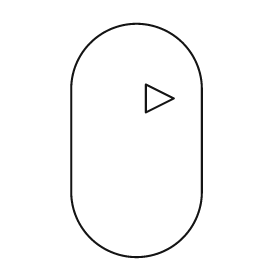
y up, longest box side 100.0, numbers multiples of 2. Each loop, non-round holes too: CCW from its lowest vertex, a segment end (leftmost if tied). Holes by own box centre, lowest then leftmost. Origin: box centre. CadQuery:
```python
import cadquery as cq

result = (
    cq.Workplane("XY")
    .moveTo(-28.0, -22.0)
    .threePointArc((0.0, -50.0), (28.0, -22.0))
    .lineTo(28.0, 22.0)
    .threePointArc((0.0, 50.0), (-28.0, 22.0))
    .close()
    .moveTo(4.0, 12.0)
    .lineTo(16.0, 18.0)
    .lineTo(4.0, 24.0)
    .close()
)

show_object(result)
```